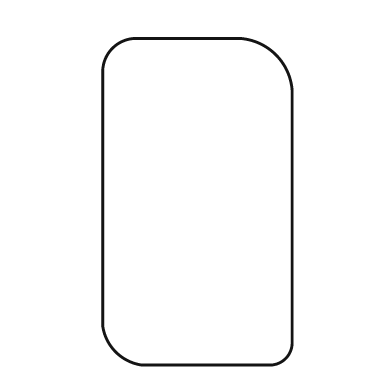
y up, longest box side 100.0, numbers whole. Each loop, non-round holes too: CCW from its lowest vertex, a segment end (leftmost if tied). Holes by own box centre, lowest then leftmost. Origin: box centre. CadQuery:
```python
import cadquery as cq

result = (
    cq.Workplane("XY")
    .moveTo(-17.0, -50.0)
    .lineTo(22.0, -50.0)
    .threePointArc((27.0, -48.0), (29.0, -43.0))
    .lineTo(29.0, 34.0)
    .threePointArc((24.0, 45.0), (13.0, 50.0))
    .lineTo(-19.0, 50.0)
    .threePointArc((-26.0, 47.0), (-29.0, 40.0))
    .lineTo(-29.0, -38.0)
    .threePointArc((-25.0, -46.0), (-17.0, -50.0))
    .close()
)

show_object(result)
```